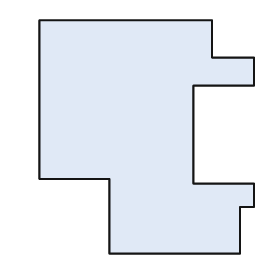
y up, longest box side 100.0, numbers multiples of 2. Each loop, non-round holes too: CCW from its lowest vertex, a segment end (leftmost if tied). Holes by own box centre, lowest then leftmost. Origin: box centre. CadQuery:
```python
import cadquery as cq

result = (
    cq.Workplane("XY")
    .moveTo(-16.0, -50.0)
    .lineTo(40.0, -50.0)
    .lineTo(40.0, -30.0)
    .lineTo(46.0, -30.0)
    .lineTo(46.0, -20.0)
    .lineTo(20.0, -20.0)
    .lineTo(20.0, 22.0)
    .lineTo(46.0, 22.0)
    .lineTo(46.0, 34.0)
    .lineTo(28.0, 34.0)
    .lineTo(28.0, 50.0)
    .lineTo(-46.0, 50.0)
    .lineTo(-46.0, -18.0)
    .lineTo(-16.0, -18.0)
    .close()
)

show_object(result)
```